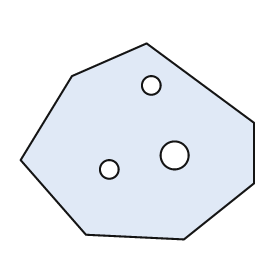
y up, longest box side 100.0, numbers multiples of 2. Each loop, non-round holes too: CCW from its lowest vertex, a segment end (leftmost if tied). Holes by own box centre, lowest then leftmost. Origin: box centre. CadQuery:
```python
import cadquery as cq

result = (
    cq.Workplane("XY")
    .moveTo(20.0, -42.0)
    .lineTo(50.0, -18.0)
    .lineTo(50.0, 8.0)
    .lineTo(4.0, 42.0)
    .lineTo(-28.0, 28.0)
    .lineTo(-50.0, -8.0)
    .lineTo(-22.0, -40.0)
    .close()
    .moveTo(-12.0, -12.0)
    .circle(4.0)
    .moveTo(16.0, -6.0)
    .circle(6.0)
    .moveTo(6.0, 24.0)
    .circle(4.0)
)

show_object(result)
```